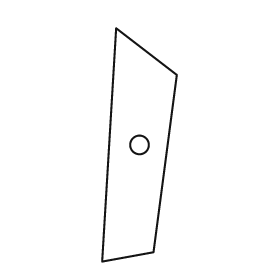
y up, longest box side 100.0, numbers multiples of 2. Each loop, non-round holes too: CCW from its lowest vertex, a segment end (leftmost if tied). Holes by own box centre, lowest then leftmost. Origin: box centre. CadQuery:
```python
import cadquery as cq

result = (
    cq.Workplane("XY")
    .moveTo(-16.0, -50.0)
    .lineTo(6.0, -46.0)
    .lineTo(16.0, 30.0)
    .lineTo(-10.0, 50.0)
    .close()
    .moveTo(0.0, 0.0)
    .circle(4.0)
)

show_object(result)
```